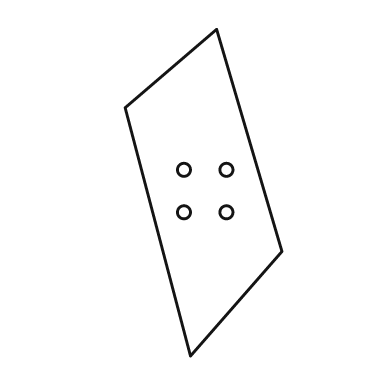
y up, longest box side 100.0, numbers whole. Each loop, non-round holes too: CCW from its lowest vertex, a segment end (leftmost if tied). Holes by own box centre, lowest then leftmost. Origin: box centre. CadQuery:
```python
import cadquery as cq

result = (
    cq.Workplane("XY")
    .moveTo(-4.0, -50.0)
    .lineTo(24.0, -18.0)
    .lineTo(4.0, 50.0)
    .lineTo(-24.0, 26.0)
    .close()
    .moveTo(-6.0, -6.0)
    .circle(2.0)
    .moveTo(7.0, -6.0)
    .circle(2.0)
    .moveTo(-6.0, 7.0)
    .circle(2.0)
    .moveTo(7.0, 7.0)
    .circle(2.0)
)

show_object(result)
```